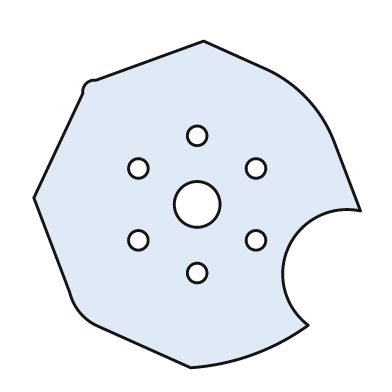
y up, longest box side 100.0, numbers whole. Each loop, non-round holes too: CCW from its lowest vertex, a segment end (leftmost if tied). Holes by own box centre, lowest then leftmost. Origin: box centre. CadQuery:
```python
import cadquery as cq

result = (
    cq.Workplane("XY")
    .moveTo(-2.0, -50.0)
    .threePointArc((17.0, -46.0), (34.0, -37.0))
    .threePointArc((28.0, -13.0), (50.0, -2.0))
    .lineTo(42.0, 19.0)
    .threePointArc((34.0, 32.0), (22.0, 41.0))
    .lineTo(2.0, 50.0)
    .lineTo(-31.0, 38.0)
    .threePointArc((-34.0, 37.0), (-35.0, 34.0))
    .lineTo(-50.0, 2.0)
    .lineTo(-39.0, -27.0)
    .threePointArc((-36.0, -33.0), (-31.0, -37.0))
    .close()
    .moveTo(0.0, -21.0)
    .circle(3.0)
    .moveTo(-18.0, -11.0)
    .circle(3.0)
    .moveTo(18.0, -11.0)
    .circle(3.0)
    .moveTo(0.0, 0.0)
    .circle(7.0)
    .moveTo(-18.0, 11.0)
    .circle(3.0)
    .moveTo(18.0, 11.0)
    .circle(3.0)
    .moveTo(0.0, 21.0)
    .circle(3.0)
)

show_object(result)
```